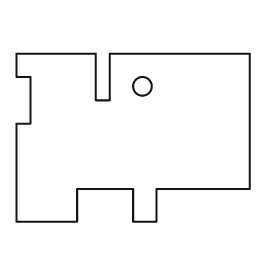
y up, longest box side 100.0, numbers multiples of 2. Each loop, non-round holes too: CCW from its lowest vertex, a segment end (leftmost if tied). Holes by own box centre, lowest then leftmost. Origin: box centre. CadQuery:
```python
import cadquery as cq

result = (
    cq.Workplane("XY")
    .moveTo(-50.0, -36.0)
    .lineTo(-24.0, -36.0)
    .lineTo(-24.0, -22.0)
    .lineTo(0.0, -22.0)
    .lineTo(0.0, -36.0)
    .lineTo(10.0, -36.0)
    .lineTo(10.0, -22.0)
    .lineTo(50.0, -22.0)
    .lineTo(50.0, 36.0)
    .lineTo(-10.0, 36.0)
    .lineTo(-10.0, 16.0)
    .lineTo(-16.0, 16.0)
    .lineTo(-16.0, 36.0)
    .lineTo(-50.0, 36.0)
    .lineTo(-50.0, 26.0)
    .lineTo(-44.0, 26.0)
    .lineTo(-44.0, 6.0)
    .lineTo(-50.0, 6.0)
    .close()
    .moveTo(4.0, 22.0)
    .circle(4.0)
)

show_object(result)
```